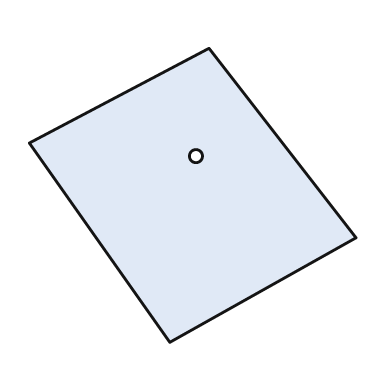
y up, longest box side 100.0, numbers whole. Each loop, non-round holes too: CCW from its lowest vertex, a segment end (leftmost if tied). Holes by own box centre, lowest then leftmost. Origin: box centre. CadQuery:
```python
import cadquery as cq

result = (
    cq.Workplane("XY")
    .moveTo(-7.0, -45.0)
    .lineTo(50.0, -13.0)
    .lineTo(5.0, 45.0)
    .lineTo(-50.0, 16.0)
    .close()
    .moveTo(1.0, 12.0)
    .circle(2.0)
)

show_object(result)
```